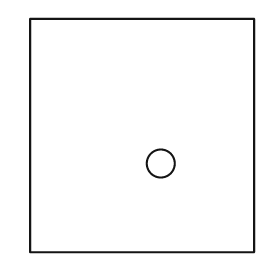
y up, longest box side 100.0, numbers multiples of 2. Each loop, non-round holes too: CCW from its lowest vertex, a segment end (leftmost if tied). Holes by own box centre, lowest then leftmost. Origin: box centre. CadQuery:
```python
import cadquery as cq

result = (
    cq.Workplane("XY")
    .moveTo(-48.0, -50.0)
    .lineTo(48.0, -50.0)
    .lineTo(48.0, 50.0)
    .lineTo(-48.0, 50.0)
    .close()
    .moveTo(8.0, -12.0)
    .circle(6.0)
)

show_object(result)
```